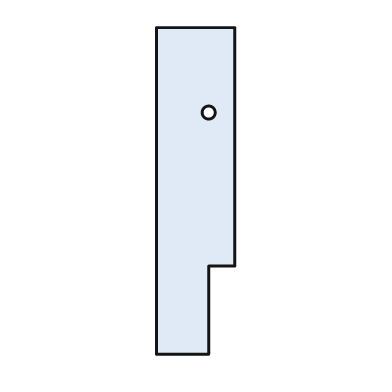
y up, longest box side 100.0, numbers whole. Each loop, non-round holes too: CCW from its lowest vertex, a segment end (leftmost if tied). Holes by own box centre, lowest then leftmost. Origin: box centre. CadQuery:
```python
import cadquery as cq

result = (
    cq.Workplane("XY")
    .moveTo(-12.0, -50.0)
    .lineTo(4.0, -50.0)
    .lineTo(4.0, -23.0)
    .lineTo(12.0, -23.0)
    .lineTo(12.0, 50.0)
    .lineTo(-12.0, 50.0)
    .close()
    .moveTo(4.0, 24.0)
    .circle(2.0)
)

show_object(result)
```